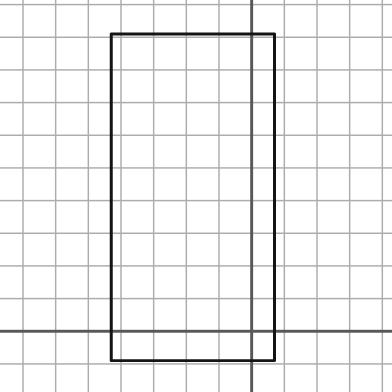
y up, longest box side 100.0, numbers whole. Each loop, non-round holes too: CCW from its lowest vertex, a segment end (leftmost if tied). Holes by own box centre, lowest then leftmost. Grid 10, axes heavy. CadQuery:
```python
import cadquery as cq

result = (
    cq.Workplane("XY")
    .moveTo(-43.0, -9.0)
    .lineTo(7.0, -9.0)
    .lineTo(7.0, 91.0)
    .lineTo(-43.0, 91.0)
    .close()
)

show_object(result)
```